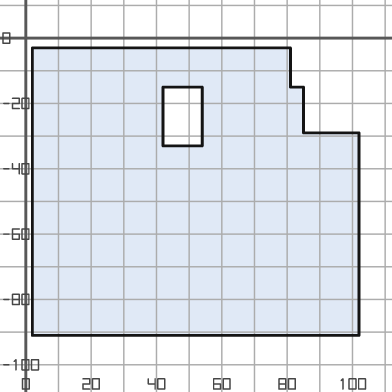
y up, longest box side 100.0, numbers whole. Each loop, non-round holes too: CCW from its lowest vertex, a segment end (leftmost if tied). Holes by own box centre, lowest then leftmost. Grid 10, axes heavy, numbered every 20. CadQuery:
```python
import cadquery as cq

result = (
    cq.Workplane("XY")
    .moveTo(2.0, -91.0)
    .lineTo(102.0, -91.0)
    .lineTo(102.0, -29.0)
    .lineTo(85.0, -29.0)
    .lineTo(85.0, -15.0)
    .lineTo(81.0, -15.0)
    .lineTo(81.0, -3.0)
    .lineTo(2.0, -3.0)
    .close()
    .moveTo(42.0, -33.0)
    .lineTo(54.0, -33.0)
    .lineTo(54.0, -15.0)
    .lineTo(42.0, -15.0)
    .close()
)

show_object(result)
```